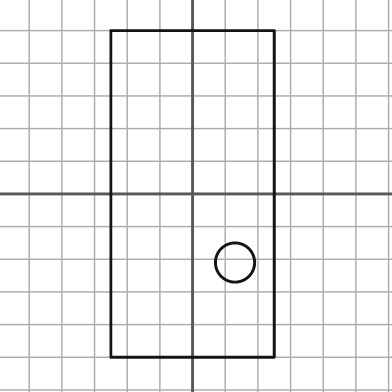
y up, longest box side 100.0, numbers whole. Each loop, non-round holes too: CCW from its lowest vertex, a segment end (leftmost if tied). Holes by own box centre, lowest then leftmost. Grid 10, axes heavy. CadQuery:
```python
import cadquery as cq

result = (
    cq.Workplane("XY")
    .moveTo(-25.0, -50.0)
    .lineTo(25.0, -50.0)
    .lineTo(25.0, 50.0)
    .lineTo(-25.0, 50.0)
    .close()
    .moveTo(13.0, -21.0)
    .circle(6.0)
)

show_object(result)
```